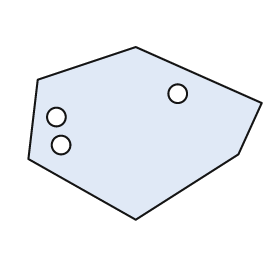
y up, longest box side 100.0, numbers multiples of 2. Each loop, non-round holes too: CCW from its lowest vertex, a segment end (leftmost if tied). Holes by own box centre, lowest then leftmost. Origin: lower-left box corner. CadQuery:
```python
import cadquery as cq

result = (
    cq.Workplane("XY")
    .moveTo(46.0, 0.0)
    .lineTo(90.0, 28.0)
    .lineTo(100.0, 50.0)
    .lineTo(46.0, 74.0)
    .lineTo(4.0, 60.0)
    .lineTo(0.0, 26.0)
    .close()
    .moveTo(14.0, 32.0)
    .circle(4.0)
    .moveTo(12.0, 44.0)
    .circle(4.0)
    .moveTo(64.0, 54.0)
    .circle(4.0)
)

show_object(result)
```